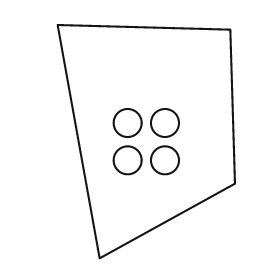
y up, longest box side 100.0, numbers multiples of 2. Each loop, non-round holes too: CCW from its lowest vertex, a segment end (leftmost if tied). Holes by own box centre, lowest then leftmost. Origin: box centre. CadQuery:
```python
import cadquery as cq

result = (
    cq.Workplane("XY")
    .moveTo(-20.0, -50.0)
    .lineTo(38.0, -18.0)
    .lineTo(36.0, 48.0)
    .lineTo(-38.0, 50.0)
    .close()
    .moveTo(-8.0, -8.0)
    .circle(6.0)
    .moveTo(8.0, -8.0)
    .circle(6.0)
    .moveTo(-8.0, 8.0)
    .circle(6.0)
    .moveTo(8.0, 8.0)
    .circle(6.0)
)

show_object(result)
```